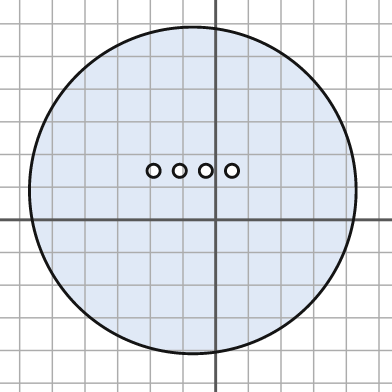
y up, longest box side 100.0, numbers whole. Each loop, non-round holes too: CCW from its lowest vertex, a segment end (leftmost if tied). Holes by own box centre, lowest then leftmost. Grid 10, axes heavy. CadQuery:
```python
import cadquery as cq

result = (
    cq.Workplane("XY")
    .moveTo(-7.0, 9.0)
    .circle(50.0)
    .moveTo(-19.0, 15.0)
    .circle(2.0)
    .moveTo(-11.0, 15.0)
    .circle(2.0)
    .moveTo(-3.0, 15.0)
    .circle(2.0)
    .moveTo(5.0, 15.0)
    .circle(2.0)
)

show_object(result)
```